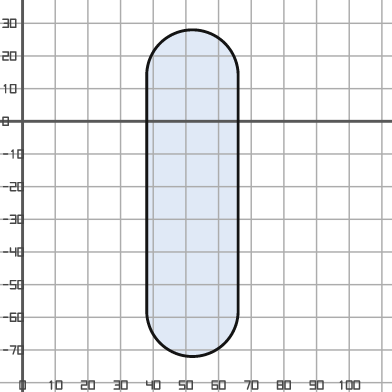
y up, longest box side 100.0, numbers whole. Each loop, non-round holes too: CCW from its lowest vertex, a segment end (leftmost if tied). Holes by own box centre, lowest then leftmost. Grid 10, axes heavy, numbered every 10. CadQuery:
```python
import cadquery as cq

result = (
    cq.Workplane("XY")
    .moveTo(38.0, -58.0)
    .threePointArc((52.0, -72.0), (66.0, -58.0))
    .lineTo(66.0, 14.0)
    .threePointArc((52.0, 28.0), (38.0, 14.0))
    .close()
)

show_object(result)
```